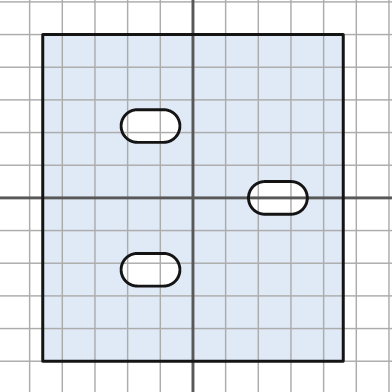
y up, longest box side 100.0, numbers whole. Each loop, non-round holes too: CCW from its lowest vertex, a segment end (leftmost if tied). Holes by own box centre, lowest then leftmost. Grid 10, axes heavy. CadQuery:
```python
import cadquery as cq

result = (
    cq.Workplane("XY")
    .moveTo(-46.0, -50.0)
    .lineTo(46.0, -50.0)
    .lineTo(46.0, 50.0)
    .lineTo(-46.0, 50.0)
    .close()
    .moveTo(-17.0, -27.0)
    .lineTo(-9.0, -27.0)
    .threePointArc((-4.0, -22.0), (-9.0, -17.0))
    .lineTo(-17.0, -17.0)
    .threePointArc((-22.0, -22.0), (-17.0, -27.0))
    .close()
    .moveTo(22.0, -5.0)
    .lineTo(30.0, -5.0)
    .threePointArc((35.0, 0.0), (30.0, 5.0))
    .lineTo(22.0, 5.0)
    .threePointArc((17.0, 0.0), (22.0, -5.0))
    .close()
    .moveTo(-17.0, 17.0)
    .lineTo(-9.0, 17.0)
    .threePointArc((-4.0, 22.0), (-9.0, 27.0))
    .lineTo(-17.0, 27.0)
    .threePointArc((-22.0, 22.0), (-17.0, 17.0))
    .close()
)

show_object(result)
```